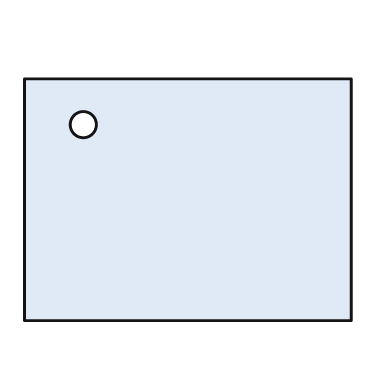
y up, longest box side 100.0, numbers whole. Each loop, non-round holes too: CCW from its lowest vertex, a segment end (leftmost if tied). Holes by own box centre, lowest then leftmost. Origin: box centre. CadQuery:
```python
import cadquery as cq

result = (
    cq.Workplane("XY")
    .moveTo(-50.0, -37.0)
    .lineTo(50.0, -37.0)
    .lineTo(50.0, 37.0)
    .lineTo(-50.0, 37.0)
    .close()
    .moveTo(-32.0, 23.0)
    .circle(4.0)
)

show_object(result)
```